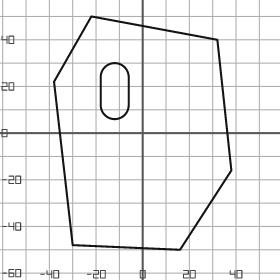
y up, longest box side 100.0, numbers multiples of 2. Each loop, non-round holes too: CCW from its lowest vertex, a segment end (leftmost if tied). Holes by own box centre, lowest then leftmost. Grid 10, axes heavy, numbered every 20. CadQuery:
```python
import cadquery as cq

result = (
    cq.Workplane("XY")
    .moveTo(16.0, -50.0)
    .lineTo(38.0, -16.0)
    .lineTo(32.0, 40.0)
    .lineTo(-22.0, 50.0)
    .lineTo(-38.0, 22.0)
    .lineTo(-30.0, -48.0)
    .close()
    .moveTo(-18.0, 12.0)
    .threePointArc((-12.0, 6.0), (-6.0, 12.0))
    .lineTo(-6.0, 24.0)
    .threePointArc((-12.0, 30.0), (-18.0, 24.0))
    .close()
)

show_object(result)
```